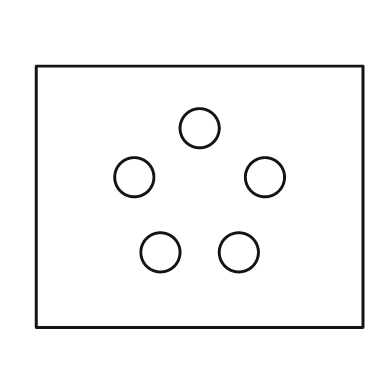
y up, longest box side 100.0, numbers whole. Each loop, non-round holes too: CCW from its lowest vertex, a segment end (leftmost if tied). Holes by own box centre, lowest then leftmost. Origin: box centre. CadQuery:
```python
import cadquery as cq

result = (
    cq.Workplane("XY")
    .moveTo(-50.0, -40.0)
    .lineTo(50.0, -40.0)
    .lineTo(50.0, 40.0)
    .lineTo(-50.0, 40.0)
    .close()
    .moveTo(-12.0, -17.0)
    .circle(6.0)
    .moveTo(12.0, -17.0)
    .circle(6.0)
    .moveTo(-20.0, 6.0)
    .circle(6.0)
    .moveTo(20.0, 6.0)
    .circle(6.0)
    .moveTo(0.0, 21.0)
    .circle(6.0)
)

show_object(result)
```